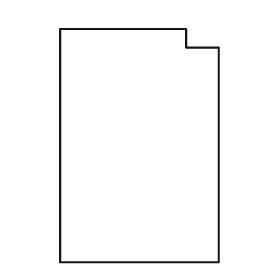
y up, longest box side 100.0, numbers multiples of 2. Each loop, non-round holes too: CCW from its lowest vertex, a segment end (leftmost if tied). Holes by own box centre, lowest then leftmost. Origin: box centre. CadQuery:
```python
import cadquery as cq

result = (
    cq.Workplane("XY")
    .moveTo(-34.0, -50.0)
    .lineTo(34.0, -50.0)
    .lineTo(34.0, 42.0)
    .lineTo(20.0, 42.0)
    .lineTo(20.0, 50.0)
    .lineTo(-34.0, 50.0)
    .close()
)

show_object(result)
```